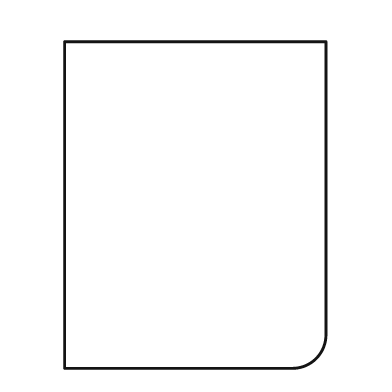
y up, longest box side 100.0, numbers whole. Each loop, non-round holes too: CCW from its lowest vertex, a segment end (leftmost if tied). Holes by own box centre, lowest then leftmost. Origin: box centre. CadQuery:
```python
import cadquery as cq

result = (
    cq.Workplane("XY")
    .moveTo(-40.0, -50.0)
    .lineTo(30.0, -50.0)
    .threePointArc((37.0, -47.0), (40.0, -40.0))
    .lineTo(40.0, 50.0)
    .lineTo(-40.0, 50.0)
    .close()
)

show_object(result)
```